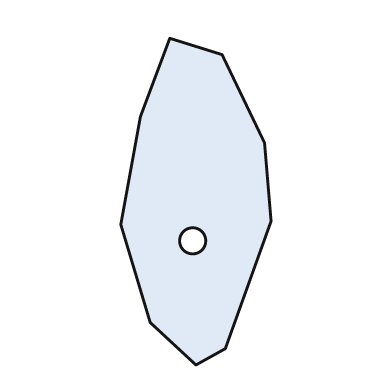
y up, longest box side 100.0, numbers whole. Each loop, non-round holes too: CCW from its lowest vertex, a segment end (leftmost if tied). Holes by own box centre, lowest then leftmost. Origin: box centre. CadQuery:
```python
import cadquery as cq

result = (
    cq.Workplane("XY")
    .moveTo(0.0, -50.0)
    .lineTo(9.0, -45.0)
    .lineTo(23.0, -6.0)
    .lineTo(21.0, 18.0)
    .lineTo(8.0, 45.0)
    .lineTo(-8.0, 50.0)
    .lineTo(-17.0, 26.0)
    .lineTo(-23.0, -7.0)
    .lineTo(-14.0, -37.0)
    .close()
    .moveTo(-1.0, -12.0)
    .circle(4.0)
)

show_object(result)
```